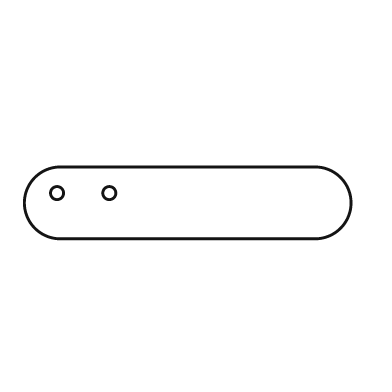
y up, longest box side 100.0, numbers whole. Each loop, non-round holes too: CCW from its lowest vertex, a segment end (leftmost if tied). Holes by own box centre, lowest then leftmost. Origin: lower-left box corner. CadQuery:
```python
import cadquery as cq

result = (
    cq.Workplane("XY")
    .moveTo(11.0, 0.0)
    .lineTo(89.0, 0.0)
    .threePointArc((100.0, 11.0), (89.0, 22.0))
    .lineTo(11.0, 22.0)
    .threePointArc((0.0, 11.0), (11.0, 0.0))
    .close()
    .moveTo(10.0, 14.0)
    .circle(2.0)
    .moveTo(26.0, 14.0)
    .circle(2.0)
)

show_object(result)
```